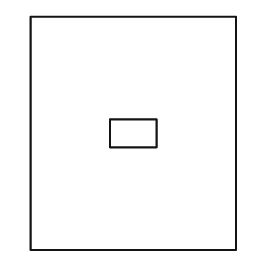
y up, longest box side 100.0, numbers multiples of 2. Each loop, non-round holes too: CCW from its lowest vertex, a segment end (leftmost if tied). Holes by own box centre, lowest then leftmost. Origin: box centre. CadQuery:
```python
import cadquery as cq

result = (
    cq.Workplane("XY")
    .moveTo(-44.0, -50.0)
    .lineTo(44.0, -50.0)
    .lineTo(44.0, 50.0)
    .lineTo(-44.0, 50.0)
    .close()
    .moveTo(-10.0, -6.0)
    .lineTo(10.0, -6.0)
    .lineTo(10.0, 6.0)
    .lineTo(-10.0, 6.0)
    .close()
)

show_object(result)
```